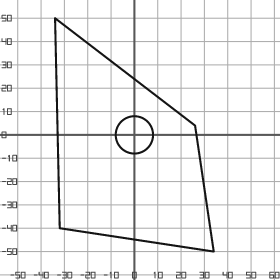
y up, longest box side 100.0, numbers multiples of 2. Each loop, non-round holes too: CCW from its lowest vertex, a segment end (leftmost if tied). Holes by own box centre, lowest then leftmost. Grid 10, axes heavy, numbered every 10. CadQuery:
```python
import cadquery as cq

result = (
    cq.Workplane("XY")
    .moveTo(34.0, -50.0)
    .lineTo(26.0, 4.0)
    .lineTo(-34.0, 50.0)
    .lineTo(-32.0, -40.0)
    .close()
    .moveTo(0.0, 0.0)
    .circle(8.0)
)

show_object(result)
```